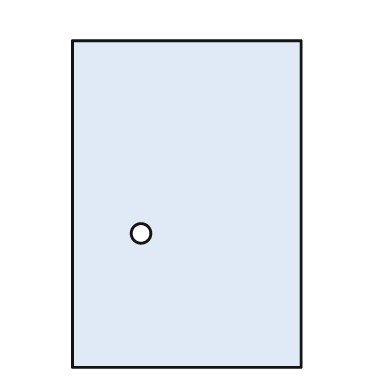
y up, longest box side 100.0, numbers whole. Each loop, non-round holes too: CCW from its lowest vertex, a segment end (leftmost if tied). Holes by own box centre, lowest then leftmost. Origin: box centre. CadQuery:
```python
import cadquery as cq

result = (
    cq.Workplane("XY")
    .moveTo(-35.0, -50.0)
    .lineTo(35.0, -50.0)
    .lineTo(35.0, 50.0)
    .lineTo(-35.0, 50.0)
    .close()
    .moveTo(-14.0, -9.0)
    .circle(3.0)
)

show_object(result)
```